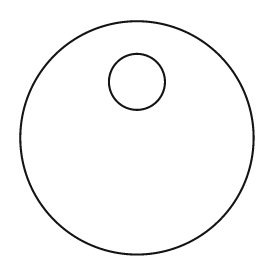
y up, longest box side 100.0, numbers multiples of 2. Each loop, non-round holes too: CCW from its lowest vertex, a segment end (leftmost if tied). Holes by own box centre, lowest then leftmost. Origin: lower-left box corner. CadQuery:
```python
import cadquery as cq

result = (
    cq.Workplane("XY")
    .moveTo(50.0, 50.0)
    .circle(50.0)
    .moveTo(50.0, 74.0)
    .circle(12.0)
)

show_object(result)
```